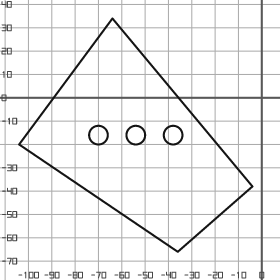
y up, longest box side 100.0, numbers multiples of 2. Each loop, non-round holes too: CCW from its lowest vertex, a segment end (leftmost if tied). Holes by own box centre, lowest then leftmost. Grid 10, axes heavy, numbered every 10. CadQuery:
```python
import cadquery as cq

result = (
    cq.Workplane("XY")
    .moveTo(-36.0, -66.0)
    .lineTo(-4.0, -38.0)
    .lineTo(-64.0, 34.0)
    .lineTo(-104.0, -20.0)
    .close()
    .moveTo(-70.0, -16.0)
    .circle(4.0)
    .moveTo(-54.0, -16.0)
    .circle(4.0)
    .moveTo(-38.0, -16.0)
    .circle(4.0)
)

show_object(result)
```